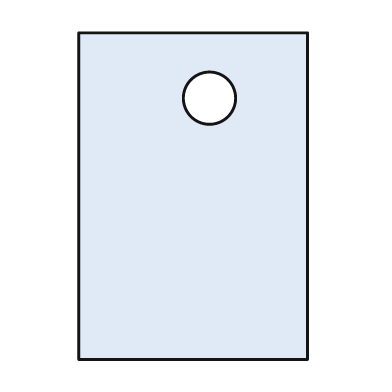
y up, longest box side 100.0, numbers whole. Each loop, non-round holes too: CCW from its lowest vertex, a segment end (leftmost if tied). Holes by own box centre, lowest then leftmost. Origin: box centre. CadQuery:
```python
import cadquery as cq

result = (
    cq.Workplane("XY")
    .moveTo(-35.0, -50.0)
    .lineTo(35.0, -50.0)
    .lineTo(35.0, 50.0)
    .lineTo(-35.0, 50.0)
    .close()
    .moveTo(5.0, 30.0)
    .circle(8.0)
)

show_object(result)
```